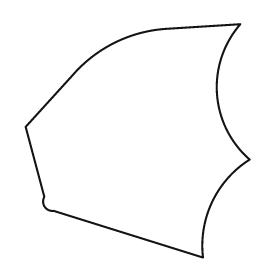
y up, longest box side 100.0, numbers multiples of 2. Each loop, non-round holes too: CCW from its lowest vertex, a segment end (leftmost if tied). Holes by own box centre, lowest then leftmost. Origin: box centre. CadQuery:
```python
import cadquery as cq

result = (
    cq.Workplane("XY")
    .moveTo(28.0, -50.0)
    .threePointArc((32.0, -26.0), (48.0, -8.0))
    .threePointArc((34.0, 20.0), (44.0, 50.0))
    .lineTo(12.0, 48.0)
    .threePointArc((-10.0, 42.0), (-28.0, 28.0))
    .lineTo(-48.0, 6.0)
    .lineTo(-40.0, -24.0)
    .threePointArc((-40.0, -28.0), (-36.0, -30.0))
    .close()
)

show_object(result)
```